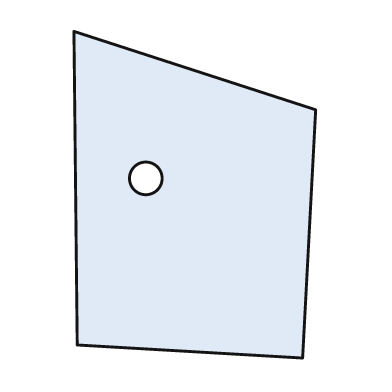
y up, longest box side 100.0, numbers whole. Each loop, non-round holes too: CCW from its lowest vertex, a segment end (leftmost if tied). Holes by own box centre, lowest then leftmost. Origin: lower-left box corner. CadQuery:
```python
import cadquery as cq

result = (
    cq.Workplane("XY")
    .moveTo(70.0, 0.0)
    .lineTo(74.0, 76.0)
    .lineTo(0.0, 100.0)
    .lineTo(1.0, 4.0)
    .close()
    .moveTo(22.0, 55.0)
    .circle(5.0)
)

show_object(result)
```